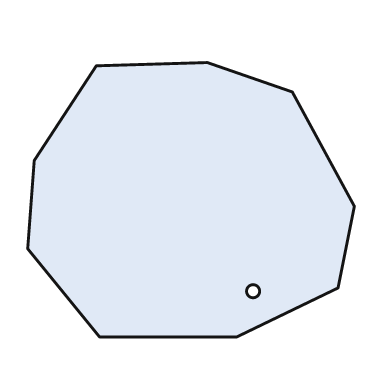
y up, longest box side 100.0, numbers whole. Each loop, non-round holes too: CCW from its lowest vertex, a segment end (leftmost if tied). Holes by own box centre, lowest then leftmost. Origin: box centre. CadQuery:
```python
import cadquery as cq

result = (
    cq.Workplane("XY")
    .moveTo(-28.0, -42.0)
    .lineTo(14.0, -42.0)
    .lineTo(45.0, -27.0)
    .lineTo(50.0, -2.0)
    .lineTo(31.0, 33.0)
    .lineTo(5.0, 42.0)
    .lineTo(-29.0, 41.0)
    .lineTo(-48.0, 12.0)
    .lineTo(-50.0, -15.0)
    .close()
    .moveTo(19.0, -28.0)
    .circle(2.0)
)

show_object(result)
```